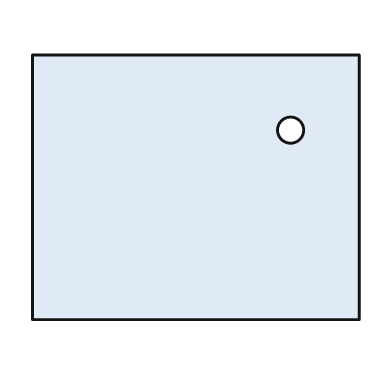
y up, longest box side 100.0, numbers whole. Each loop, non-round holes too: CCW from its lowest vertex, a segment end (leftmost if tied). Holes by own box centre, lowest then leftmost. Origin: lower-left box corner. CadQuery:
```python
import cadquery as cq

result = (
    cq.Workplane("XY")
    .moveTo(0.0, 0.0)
    .lineTo(100.0, 0.0)
    .lineTo(100.0, 81.0)
    .lineTo(0.0, 81.0)
    .close()
    .moveTo(79.0, 58.0)
    .circle(4.0)
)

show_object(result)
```